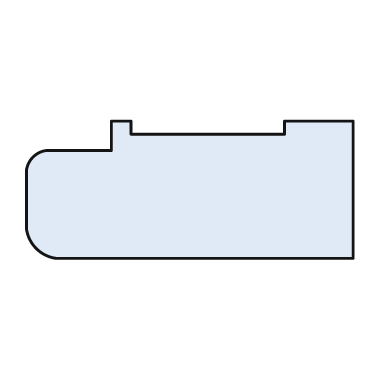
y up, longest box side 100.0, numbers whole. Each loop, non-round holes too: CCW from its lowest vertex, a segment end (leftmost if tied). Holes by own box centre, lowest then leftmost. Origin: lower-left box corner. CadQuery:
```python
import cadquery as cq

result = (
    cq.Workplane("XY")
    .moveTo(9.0, 0.0)
    .lineTo(100.0, 0.0)
    .lineTo(100.0, 42.0)
    .lineTo(79.0, 42.0)
    .lineTo(79.0, 38.0)
    .lineTo(32.0, 38.0)
    .lineTo(32.0, 42.0)
    .lineTo(26.0, 42.0)
    .lineTo(26.0, 33.0)
    .lineTo(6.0, 33.0)
    .threePointArc((2.0, 31.0), (0.0, 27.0))
    .lineTo(0.0, 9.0)
    .threePointArc((3.0, 3.0), (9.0, 0.0))
    .close()
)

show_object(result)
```